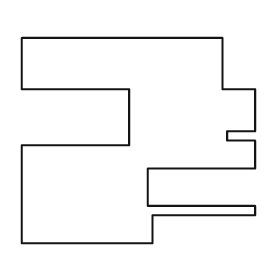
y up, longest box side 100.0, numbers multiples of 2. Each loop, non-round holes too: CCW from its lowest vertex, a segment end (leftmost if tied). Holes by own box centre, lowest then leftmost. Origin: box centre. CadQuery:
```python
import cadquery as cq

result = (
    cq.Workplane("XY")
    .moveTo(-50.0, -44.0)
    .lineTo(6.0, -44.0)
    .lineTo(6.0, -32.0)
    .lineTo(50.0, -32.0)
    .lineTo(50.0, -28.0)
    .lineTo(4.0, -28.0)
    .lineTo(4.0, -12.0)
    .lineTo(50.0, -12.0)
    .lineTo(50.0, 0.0)
    .lineTo(38.0, 0.0)
    .lineTo(38.0, 4.0)
    .lineTo(50.0, 4.0)
    .lineTo(50.0, 22.0)
    .lineTo(36.0, 22.0)
    .lineTo(36.0, 44.0)
    .lineTo(-50.0, 44.0)
    .lineTo(-50.0, 22.0)
    .lineTo(-4.0, 22.0)
    .lineTo(-4.0, -2.0)
    .lineTo(-50.0, -2.0)
    .close()
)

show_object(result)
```